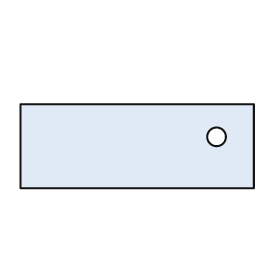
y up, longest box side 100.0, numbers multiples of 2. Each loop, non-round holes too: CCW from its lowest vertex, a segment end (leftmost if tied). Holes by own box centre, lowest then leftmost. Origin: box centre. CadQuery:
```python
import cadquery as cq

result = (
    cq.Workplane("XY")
    .moveTo(-50.0, -18.0)
    .lineTo(50.0, -18.0)
    .lineTo(50.0, 18.0)
    .lineTo(-50.0, 18.0)
    .close()
    .moveTo(34.0, 4.0)
    .circle(4.0)
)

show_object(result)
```